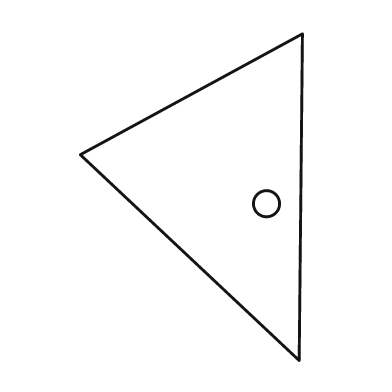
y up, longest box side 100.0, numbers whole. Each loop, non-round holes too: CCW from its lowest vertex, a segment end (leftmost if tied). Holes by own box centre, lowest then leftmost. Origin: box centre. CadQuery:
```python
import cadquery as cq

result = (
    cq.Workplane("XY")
    .moveTo(33.0, -50.0)
    .lineTo(34.0, 50.0)
    .lineTo(-34.0, 13.0)
    .close()
    .moveTo(23.0, -2.0)
    .circle(4.0)
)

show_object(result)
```